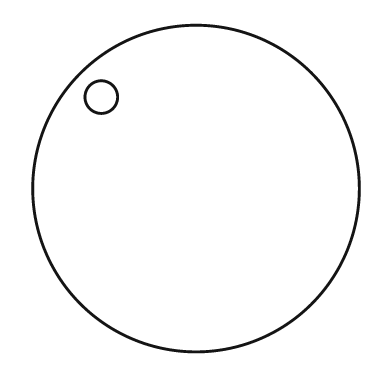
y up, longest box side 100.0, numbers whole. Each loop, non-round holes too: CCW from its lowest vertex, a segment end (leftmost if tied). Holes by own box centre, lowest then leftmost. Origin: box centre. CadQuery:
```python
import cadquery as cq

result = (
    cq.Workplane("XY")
    .moveTo(0.0, 0.0)
    .circle(50.0)
    .moveTo(-29.0, 28.0)
    .circle(5.0)
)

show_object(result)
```